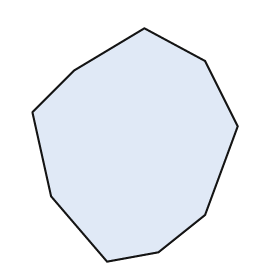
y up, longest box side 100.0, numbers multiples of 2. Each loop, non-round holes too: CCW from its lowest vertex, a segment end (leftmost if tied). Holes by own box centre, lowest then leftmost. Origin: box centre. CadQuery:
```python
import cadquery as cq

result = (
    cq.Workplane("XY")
    .moveTo(-12.0, -50.0)
    .lineTo(10.0, -46.0)
    .lineTo(30.0, -30.0)
    .lineTo(44.0, 8.0)
    .lineTo(30.0, 36.0)
    .lineTo(4.0, 50.0)
    .lineTo(-26.0, 32.0)
    .lineTo(-44.0, 14.0)
    .lineTo(-36.0, -22.0)
    .close()
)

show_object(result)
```